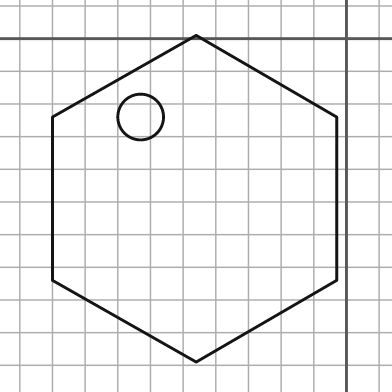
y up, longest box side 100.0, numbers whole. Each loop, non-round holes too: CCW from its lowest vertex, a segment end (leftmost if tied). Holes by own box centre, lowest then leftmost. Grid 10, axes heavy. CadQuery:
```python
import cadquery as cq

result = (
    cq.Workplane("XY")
    .moveTo(-46.0, -99.0)
    .lineTo(-3.0, -74.0)
    .lineTo(-3.0, -24.0)
    .lineTo(-46.0, 1.0)
    .lineTo(-90.0, -24.0)
    .lineTo(-90.0, -74.0)
    .close()
    .moveTo(-63.0, -24.0)
    .circle(7.0)
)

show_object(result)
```